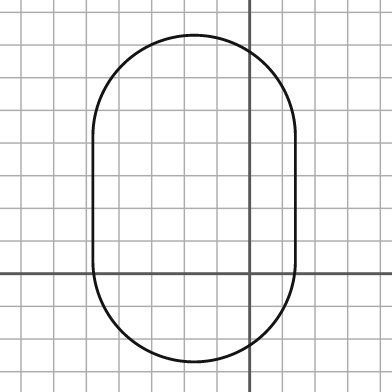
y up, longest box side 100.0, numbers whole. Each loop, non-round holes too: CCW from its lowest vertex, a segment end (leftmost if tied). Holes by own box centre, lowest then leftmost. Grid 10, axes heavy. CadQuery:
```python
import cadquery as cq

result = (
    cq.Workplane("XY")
    .moveTo(-48.0, 4.0)
    .threePointArc((-17.0, -27.0), (14.0, 4.0))
    .lineTo(14.0, 42.0)
    .threePointArc((-17.0, 73.0), (-48.0, 42.0))
    .close()
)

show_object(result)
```